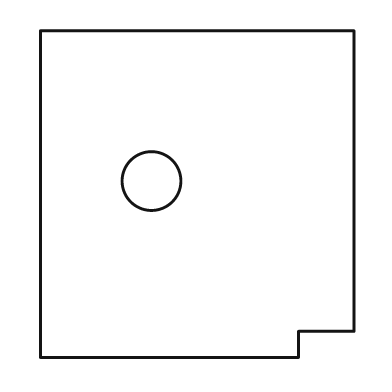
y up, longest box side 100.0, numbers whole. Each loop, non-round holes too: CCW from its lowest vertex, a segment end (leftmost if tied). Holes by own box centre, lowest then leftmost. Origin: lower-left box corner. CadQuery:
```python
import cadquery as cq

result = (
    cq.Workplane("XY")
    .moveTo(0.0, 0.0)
    .lineTo(79.0, 0.0)
    .lineTo(79.0, 8.0)
    .lineTo(96.0, 8.0)
    .lineTo(96.0, 100.0)
    .lineTo(0.0, 100.0)
    .close()
    .moveTo(34.0, 54.0)
    .circle(9.0)
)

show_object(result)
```